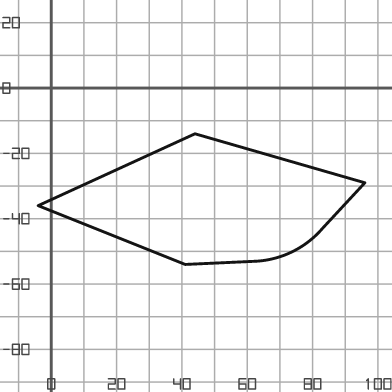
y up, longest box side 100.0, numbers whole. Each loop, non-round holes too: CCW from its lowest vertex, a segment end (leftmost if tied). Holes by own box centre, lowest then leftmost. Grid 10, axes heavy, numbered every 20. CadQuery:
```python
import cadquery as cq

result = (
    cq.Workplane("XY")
    .moveTo(41.0, -54.0)
    .lineTo(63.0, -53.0)
    .threePointArc((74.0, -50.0), (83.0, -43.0))
    .lineTo(96.0, -29.0)
    .lineTo(44.0, -14.0)
    .lineTo(-4.0, -36.0)
    .close()
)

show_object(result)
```